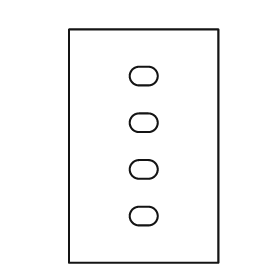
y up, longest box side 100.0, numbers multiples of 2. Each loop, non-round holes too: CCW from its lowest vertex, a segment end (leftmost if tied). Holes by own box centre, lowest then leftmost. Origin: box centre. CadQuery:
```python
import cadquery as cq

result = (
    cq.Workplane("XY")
    .moveTo(-32.0, -50.0)
    .lineTo(32.0, -50.0)
    .lineTo(32.0, 50.0)
    .lineTo(-32.0, 50.0)
    .close()
    .moveTo(-2.0, -34.0)
    .lineTo(2.0, -34.0)
    .threePointArc((6.0, -30.0), (2.0, -26.0))
    .lineTo(-2.0, -26.0)
    .threePointArc((-6.0, -30.0), (-2.0, -34.0))
    .close()
    .moveTo(-2.0, -14.0)
    .lineTo(2.0, -14.0)
    .threePointArc((6.0, -10.0), (2.0, -6.0))
    .lineTo(-2.0, -6.0)
    .threePointArc((-6.0, -10.0), (-2.0, -14.0))
    .close()
    .moveTo(-2.0, 6.0)
    .lineTo(2.0, 6.0)
    .threePointArc((6.0, 10.0), (2.0, 14.0))
    .lineTo(-2.0, 14.0)
    .threePointArc((-6.0, 10.0), (-2.0, 6.0))
    .close()
    .moveTo(-2.0, 26.0)
    .lineTo(2.0, 26.0)
    .threePointArc((6.0, 30.0), (2.0, 34.0))
    .lineTo(-2.0, 34.0)
    .threePointArc((-6.0, 30.0), (-2.0, 26.0))
    .close()
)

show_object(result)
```